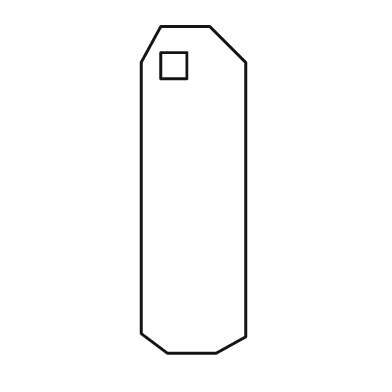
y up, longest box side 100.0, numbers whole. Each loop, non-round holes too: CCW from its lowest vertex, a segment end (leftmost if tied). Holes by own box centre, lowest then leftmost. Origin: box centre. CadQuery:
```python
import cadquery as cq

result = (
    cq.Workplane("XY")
    .moveTo(-8.0, -50.0)
    .lineTo(7.0, -50.0)
    .lineTo(16.0, -45.0)
    .lineTo(16.0, 39.0)
    .lineTo(5.0, 50.0)
    .lineTo(-10.0, 50.0)
    .lineTo(-16.0, 39.0)
    .lineTo(-16.0, -44.0)
    .close()
    .moveTo(-10.0, 34.0)
    .lineTo(-2.0, 34.0)
    .lineTo(-2.0, 42.0)
    .lineTo(-10.0, 42.0)
    .close()
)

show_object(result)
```